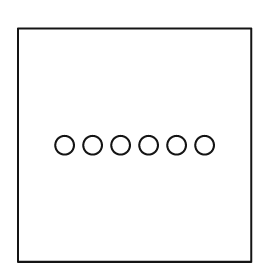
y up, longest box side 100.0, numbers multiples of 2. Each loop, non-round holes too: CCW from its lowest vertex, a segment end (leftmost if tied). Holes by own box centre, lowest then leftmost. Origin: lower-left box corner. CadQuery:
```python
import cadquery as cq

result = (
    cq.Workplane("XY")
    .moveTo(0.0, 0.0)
    .lineTo(100.0, 0.0)
    .lineTo(100.0, 100.0)
    .lineTo(0.0, 100.0)
    .close()
    .moveTo(20.0, 50.0)
    .circle(4.0)
    .moveTo(32.0, 50.0)
    .circle(4.0)
    .moveTo(44.0, 50.0)
    .circle(4.0)
    .moveTo(56.0, 50.0)
    .circle(4.0)
    .moveTo(68.0, 50.0)
    .circle(4.0)
    .moveTo(80.0, 50.0)
    .circle(4.0)
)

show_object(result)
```